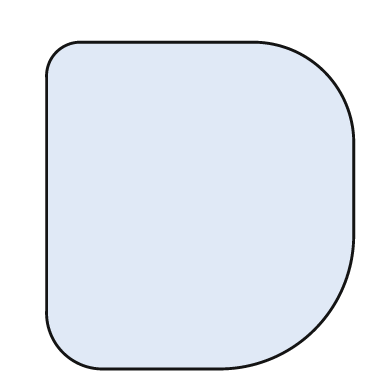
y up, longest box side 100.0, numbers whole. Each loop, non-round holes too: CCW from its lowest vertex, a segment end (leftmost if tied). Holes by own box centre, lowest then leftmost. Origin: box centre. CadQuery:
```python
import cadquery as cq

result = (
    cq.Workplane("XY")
    .moveTo(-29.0, -50.0)
    .lineTo(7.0, -50.0)
    .threePointArc((35.0, -38.0), (47.0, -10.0))
    .lineTo(47.0, 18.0)
    .threePointArc((38.0, 41.0), (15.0, 50.0))
    .lineTo(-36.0, 50.0)
    .threePointArc((-44.0, 47.0), (-47.0, 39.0))
    .lineTo(-47.0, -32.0)
    .threePointArc((-42.0, -45.0), (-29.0, -50.0))
    .close()
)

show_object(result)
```